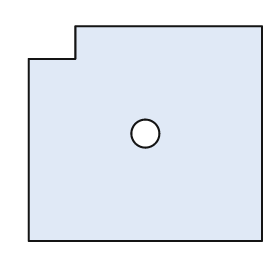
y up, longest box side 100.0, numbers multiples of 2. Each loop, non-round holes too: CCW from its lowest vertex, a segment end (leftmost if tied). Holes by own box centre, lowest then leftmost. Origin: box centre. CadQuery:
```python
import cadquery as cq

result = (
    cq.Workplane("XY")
    .moveTo(-50.0, -46.0)
    .lineTo(50.0, -46.0)
    .lineTo(50.0, 46.0)
    .lineTo(-30.0, 46.0)
    .lineTo(-30.0, 32.0)
    .lineTo(-50.0, 32.0)
    .close()
    .moveTo(0.0, 0.0)
    .circle(6.0)
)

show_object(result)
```